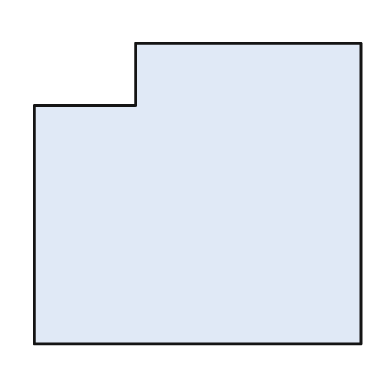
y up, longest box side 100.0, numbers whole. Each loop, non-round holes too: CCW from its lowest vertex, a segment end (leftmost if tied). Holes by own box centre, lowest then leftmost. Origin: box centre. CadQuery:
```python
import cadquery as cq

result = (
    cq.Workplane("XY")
    .moveTo(-50.0, -46.0)
    .lineTo(50.0, -46.0)
    .lineTo(50.0, 46.0)
    .lineTo(-19.0, 46.0)
    .lineTo(-19.0, 27.0)
    .lineTo(-50.0, 27.0)
    .close()
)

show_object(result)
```